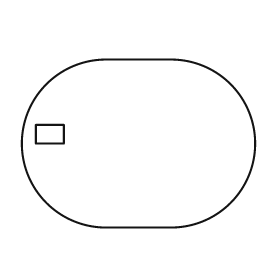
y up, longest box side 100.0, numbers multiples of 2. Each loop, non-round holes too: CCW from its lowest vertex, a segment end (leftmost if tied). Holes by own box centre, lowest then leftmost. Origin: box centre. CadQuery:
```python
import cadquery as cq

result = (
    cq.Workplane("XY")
    .moveTo(-14.0, -36.0)
    .lineTo(14.0, -36.0)
    .threePointArc((50.0, 0.0), (14.0, 36.0))
    .lineTo(-14.0, 36.0)
    .threePointArc((-50.0, 0.0), (-14.0, -36.0))
    .close()
    .moveTo(-44.0, 0.0)
    .lineTo(-32.0, 0.0)
    .lineTo(-32.0, 8.0)
    .lineTo(-44.0, 8.0)
    .close()
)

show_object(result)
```